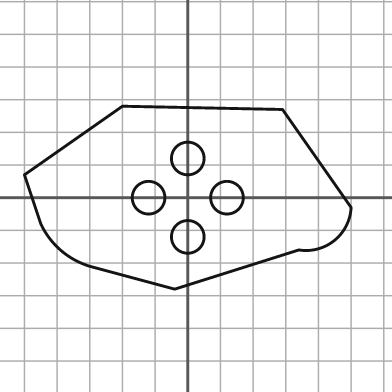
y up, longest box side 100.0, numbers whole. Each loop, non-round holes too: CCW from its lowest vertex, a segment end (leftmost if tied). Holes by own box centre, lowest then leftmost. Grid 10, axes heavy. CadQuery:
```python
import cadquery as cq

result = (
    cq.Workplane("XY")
    .moveTo(-4.0, -28.0)
    .lineTo(34.0, -16.0)
    .threePointArc((45.0, -13.0), (50.0, -3.0))
    .lineTo(29.0, 27.0)
    .lineTo(-20.0, 28.0)
    .lineTo(-50.0, 7.0)
    .lineTo(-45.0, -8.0)
    .threePointArc((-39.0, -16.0), (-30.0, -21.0))
    .close()
    .moveTo(0.0, -12.0)
    .circle(5.0)
    .moveTo(-12.0, 0.0)
    .circle(5.0)
    .moveTo(12.0, 0.0)
    .circle(5.0)
    .moveTo(0.0, 12.0)
    .circle(5.0)
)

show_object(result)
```